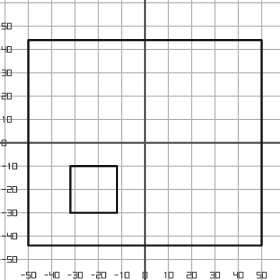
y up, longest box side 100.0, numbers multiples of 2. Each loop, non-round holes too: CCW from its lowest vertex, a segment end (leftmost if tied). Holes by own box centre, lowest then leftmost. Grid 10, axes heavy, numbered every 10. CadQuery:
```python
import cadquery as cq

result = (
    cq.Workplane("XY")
    .moveTo(-50.0, -44.0)
    .lineTo(50.0, -44.0)
    .lineTo(50.0, 44.0)
    .lineTo(-50.0, 44.0)
    .close()
    .moveTo(-32.0, -30.0)
    .lineTo(-12.0, -30.0)
    .lineTo(-12.0, -10.0)
    .lineTo(-32.0, -10.0)
    .close()
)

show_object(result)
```